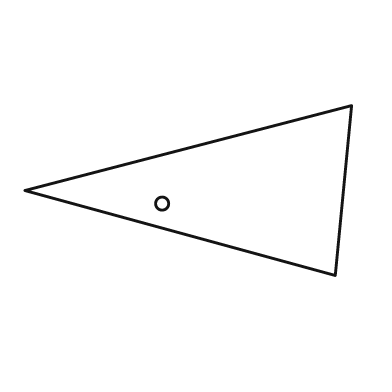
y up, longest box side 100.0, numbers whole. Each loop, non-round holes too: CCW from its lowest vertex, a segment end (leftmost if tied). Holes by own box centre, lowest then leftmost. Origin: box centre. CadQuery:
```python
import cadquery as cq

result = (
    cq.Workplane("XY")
    .moveTo(45.0, -26.0)
    .lineTo(50.0, 26.0)
    .lineTo(-50.0, 0.0)
    .close()
    .moveTo(-8.0, -4.0)
    .circle(2.0)
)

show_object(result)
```